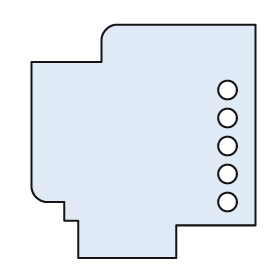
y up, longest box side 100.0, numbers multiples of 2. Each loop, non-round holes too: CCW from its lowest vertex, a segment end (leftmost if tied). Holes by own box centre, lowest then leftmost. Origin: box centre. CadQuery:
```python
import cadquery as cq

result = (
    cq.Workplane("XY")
    .moveTo(-28.0, -50.0)
    .lineTo(14.0, -50.0)
    .lineTo(14.0, -36.0)
    .lineTo(48.0, -36.0)
    .lineTo(48.0, 50.0)
    .lineTo(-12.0, 50.0)
    .threePointArc((-16.0, 48.0), (-18.0, 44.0))
    .lineTo(-18.0, 34.0)
    .lineTo(-48.0, 34.0)
    .lineTo(-48.0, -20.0)
    .threePointArc((-46.0, -24.0), (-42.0, -26.0))
    .lineTo(-34.0, -26.0)
    .lineTo(-34.0, -34.0)
    .lineTo(-28.0, -34.0)
    .close()
    .moveTo(36.0, -26.0)
    .circle(4.0)
    .moveTo(36.0, -14.0)
    .circle(4.0)
    .moveTo(36.0, -2.0)
    .circle(4.0)
    .moveTo(36.0, 10.0)
    .circle(4.0)
    .moveTo(36.0, 22.0)
    .circle(4.0)
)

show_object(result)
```